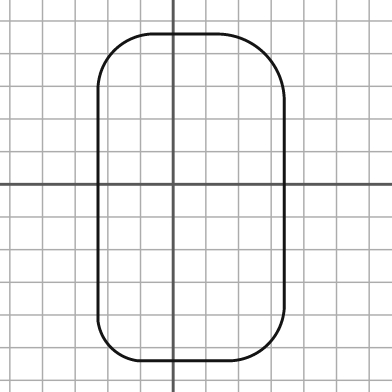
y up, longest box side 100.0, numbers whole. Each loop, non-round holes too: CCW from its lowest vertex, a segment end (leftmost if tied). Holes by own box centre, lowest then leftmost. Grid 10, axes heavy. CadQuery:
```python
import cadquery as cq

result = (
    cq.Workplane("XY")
    .moveTo(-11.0, -54.0)
    .lineTo(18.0, -54.0)
    .threePointArc((29.0, -49.0), (34.0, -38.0))
    .lineTo(34.0, 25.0)
    .threePointArc((28.0, 40.0), (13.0, 46.0))
    .lineTo(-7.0, 46.0)
    .threePointArc((-18.0, 41.0), (-23.0, 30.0))
    .lineTo(-23.0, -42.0)
    .threePointArc((-19.0, -50.0), (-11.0, -54.0))
    .close()
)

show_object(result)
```